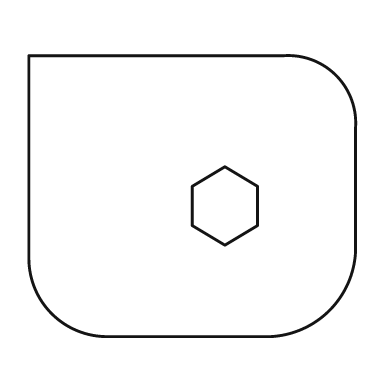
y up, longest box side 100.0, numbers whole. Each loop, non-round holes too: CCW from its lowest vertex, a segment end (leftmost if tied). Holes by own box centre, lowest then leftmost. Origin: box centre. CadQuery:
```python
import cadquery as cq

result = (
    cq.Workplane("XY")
    .moveTo(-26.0, -43.0)
    .lineTo(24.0, -43.0)
    .threePointArc((42.0, -35.0), (50.0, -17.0))
    .lineTo(50.0, 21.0)
    .threePointArc((44.0, 37.0), (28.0, 43.0))
    .lineTo(-50.0, 43.0)
    .lineTo(-50.0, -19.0)
    .threePointArc((-43.0, -36.0), (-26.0, -43.0))
    .close()
    .moveTo(10.0, -15.0)
    .lineTo(20.0, -9.0)
    .lineTo(20.0, 3.0)
    .lineTo(10.0, 9.0)
    .lineTo(0.0, 3.0)
    .lineTo(0.0, -9.0)
    .close()
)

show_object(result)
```